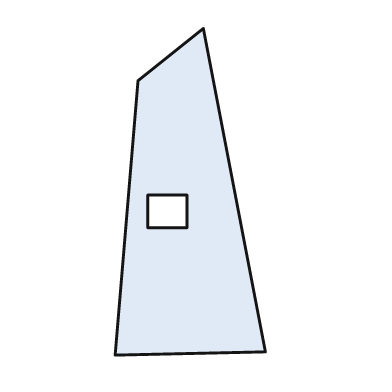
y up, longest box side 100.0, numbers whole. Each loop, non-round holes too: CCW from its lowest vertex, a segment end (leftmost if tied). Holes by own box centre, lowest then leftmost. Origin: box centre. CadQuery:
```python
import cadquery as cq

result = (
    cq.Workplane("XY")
    .moveTo(-23.0, -50.0)
    .lineTo(23.0, -49.0)
    .lineTo(4.0, 50.0)
    .lineTo(-16.0, 34.0)
    .close()
    .moveTo(-13.0, -11.0)
    .lineTo(-1.0, -11.0)
    .lineTo(-1.0, -1.0)
    .lineTo(-13.0, -1.0)
    .close()
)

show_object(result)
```